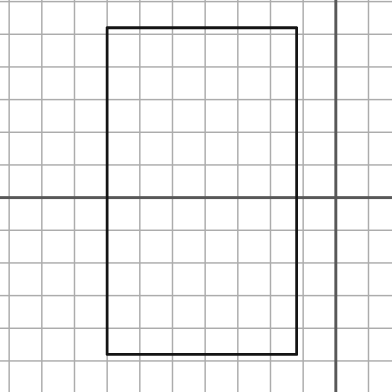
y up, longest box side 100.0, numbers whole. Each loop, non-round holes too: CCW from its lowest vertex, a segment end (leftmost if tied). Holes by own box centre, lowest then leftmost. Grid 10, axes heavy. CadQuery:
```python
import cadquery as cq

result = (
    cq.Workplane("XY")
    .moveTo(-70.0, -48.0)
    .lineTo(-12.0, -48.0)
    .lineTo(-12.0, 52.0)
    .lineTo(-70.0, 52.0)
    .close()
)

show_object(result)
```